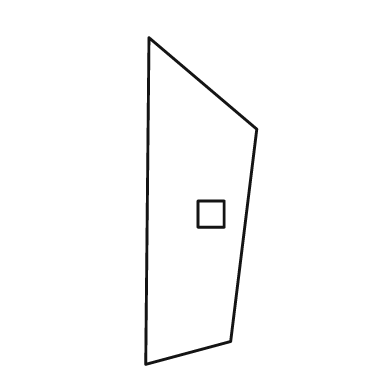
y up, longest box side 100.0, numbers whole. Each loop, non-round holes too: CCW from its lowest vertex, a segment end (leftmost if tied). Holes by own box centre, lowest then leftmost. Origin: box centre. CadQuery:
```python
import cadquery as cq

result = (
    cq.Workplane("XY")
    .moveTo(-17.0, -50.0)
    .lineTo(9.0, -43.0)
    .lineTo(17.0, 22.0)
    .lineTo(-16.0, 50.0)
    .close()
    .moveTo(-1.0, -8.0)
    .lineTo(7.0, -8.0)
    .lineTo(7.0, 0.0)
    .lineTo(-1.0, 0.0)
    .close()
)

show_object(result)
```